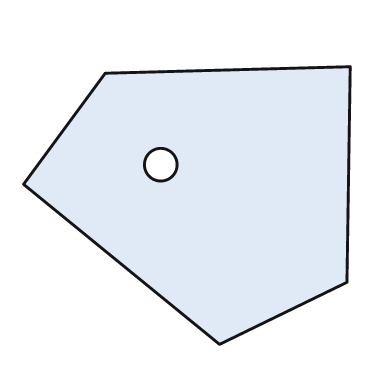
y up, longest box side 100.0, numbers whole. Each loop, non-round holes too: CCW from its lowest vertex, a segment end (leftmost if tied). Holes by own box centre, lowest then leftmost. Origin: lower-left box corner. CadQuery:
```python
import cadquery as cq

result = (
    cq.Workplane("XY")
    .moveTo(60.0, 0.0)
    .lineTo(99.0, 19.0)
    .lineTo(100.0, 85.0)
    .lineTo(25.0, 83.0)
    .lineTo(0.0, 49.0)
    .close()
    .moveTo(42.0, 55.0)
    .circle(5.0)
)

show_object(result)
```